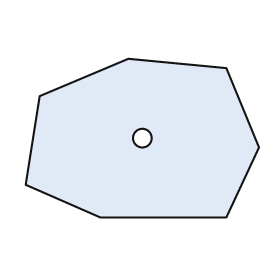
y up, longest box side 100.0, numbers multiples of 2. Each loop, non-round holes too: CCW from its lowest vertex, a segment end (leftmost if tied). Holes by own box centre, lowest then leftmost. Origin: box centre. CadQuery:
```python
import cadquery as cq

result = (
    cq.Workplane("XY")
    .moveTo(-18.0, -34.0)
    .lineTo(36.0, -34.0)
    .lineTo(50.0, -4.0)
    .lineTo(36.0, 30.0)
    .lineTo(-6.0, 34.0)
    .lineTo(-44.0, 18.0)
    .lineTo(-50.0, -20.0)
    .close()
    .moveTo(0.0, 0.0)
    .circle(4.0)
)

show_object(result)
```